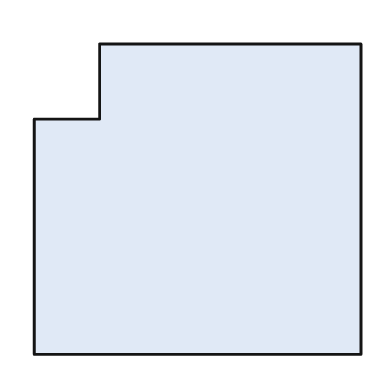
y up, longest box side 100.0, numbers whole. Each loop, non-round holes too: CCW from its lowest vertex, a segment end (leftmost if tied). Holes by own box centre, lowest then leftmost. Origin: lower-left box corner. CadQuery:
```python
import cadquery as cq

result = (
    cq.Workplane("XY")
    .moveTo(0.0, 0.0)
    .lineTo(100.0, 0.0)
    .lineTo(100.0, 95.0)
    .lineTo(20.0, 95.0)
    .lineTo(20.0, 72.0)
    .lineTo(0.0, 72.0)
    .close()
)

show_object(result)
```